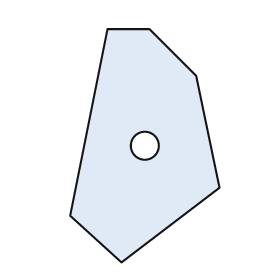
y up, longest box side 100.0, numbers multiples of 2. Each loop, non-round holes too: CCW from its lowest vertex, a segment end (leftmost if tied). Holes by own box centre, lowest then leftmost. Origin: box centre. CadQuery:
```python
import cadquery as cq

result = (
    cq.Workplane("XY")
    .moveTo(-10.0, -50.0)
    .lineTo(32.0, -18.0)
    .lineTo(22.0, 30.0)
    .lineTo(2.0, 50.0)
    .lineTo(-16.0, 50.0)
    .lineTo(-32.0, -30.0)
    .close()
    .moveTo(0.0, 0.0)
    .circle(6.0)
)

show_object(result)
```